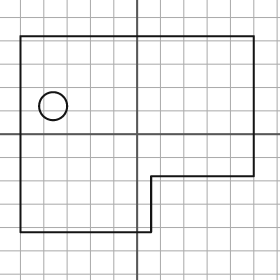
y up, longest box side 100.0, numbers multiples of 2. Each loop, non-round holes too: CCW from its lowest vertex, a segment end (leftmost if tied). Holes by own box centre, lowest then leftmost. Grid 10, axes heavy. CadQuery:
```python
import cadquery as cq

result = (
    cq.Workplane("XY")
    .moveTo(-50.0, -42.0)
    .lineTo(6.0, -42.0)
    .lineTo(6.0, -18.0)
    .lineTo(50.0, -18.0)
    .lineTo(50.0, 42.0)
    .lineTo(-50.0, 42.0)
    .close()
    .moveTo(-36.0, 12.0)
    .circle(6.0)
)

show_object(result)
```